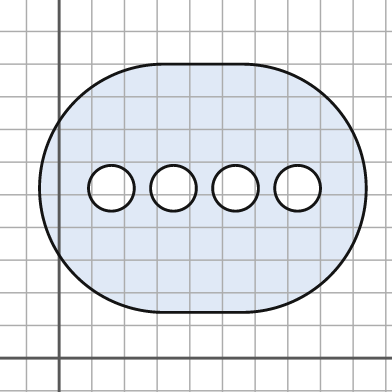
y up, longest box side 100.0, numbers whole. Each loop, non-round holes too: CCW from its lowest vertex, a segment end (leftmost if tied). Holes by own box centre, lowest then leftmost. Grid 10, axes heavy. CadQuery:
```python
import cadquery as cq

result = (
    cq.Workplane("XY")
    .moveTo(32.0, 14.0)
    .lineTo(56.0, 14.0)
    .threePointArc((94.0, 52.0), (56.0, 90.0))
    .lineTo(32.0, 90.0)
    .threePointArc((-6.0, 52.0), (32.0, 14.0))
    .close()
    .moveTo(16.0, 52.0)
    .circle(7.0)
    .moveTo(35.0, 52.0)
    .circle(7.0)
    .moveTo(54.0, 52.0)
    .circle(7.0)
    .moveTo(73.0, 52.0)
    .circle(7.0)
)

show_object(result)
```